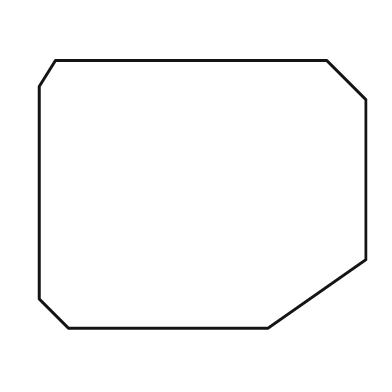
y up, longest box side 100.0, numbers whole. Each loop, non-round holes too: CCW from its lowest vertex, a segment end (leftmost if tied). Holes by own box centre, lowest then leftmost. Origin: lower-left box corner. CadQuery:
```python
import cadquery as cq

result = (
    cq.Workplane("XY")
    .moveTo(9.0, 0.0)
    .lineTo(70.0, 0.0)
    .lineTo(100.0, 21.0)
    .lineTo(100.0, 70.0)
    .lineTo(88.0, 82.0)
    .lineTo(5.0, 82.0)
    .lineTo(0.0, 74.0)
    .lineTo(0.0, 9.0)
    .close()
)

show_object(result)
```